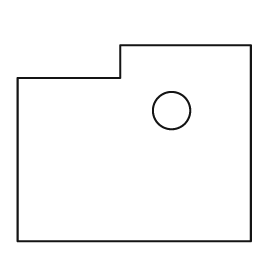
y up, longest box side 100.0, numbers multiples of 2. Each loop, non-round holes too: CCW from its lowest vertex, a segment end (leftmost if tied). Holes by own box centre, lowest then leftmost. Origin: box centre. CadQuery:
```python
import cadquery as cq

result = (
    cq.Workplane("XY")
    .moveTo(-50.0, -42.0)
    .lineTo(50.0, -42.0)
    .lineTo(50.0, 42.0)
    .lineTo(-6.0, 42.0)
    .lineTo(-6.0, 28.0)
    .lineTo(-50.0, 28.0)
    .close()
    .moveTo(16.0, 14.0)
    .circle(8.0)
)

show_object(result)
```